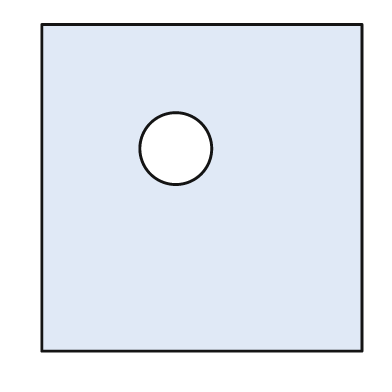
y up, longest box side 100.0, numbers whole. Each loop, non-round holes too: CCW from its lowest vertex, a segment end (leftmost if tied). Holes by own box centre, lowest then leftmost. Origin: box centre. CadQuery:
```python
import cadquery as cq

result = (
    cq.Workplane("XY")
    .moveTo(-49.0, -50.0)
    .lineTo(49.0, -50.0)
    .lineTo(49.0, 50.0)
    .lineTo(-49.0, 50.0)
    .close()
    .moveTo(-8.0, 12.0)
    .circle(11.0)
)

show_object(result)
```